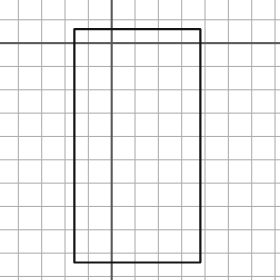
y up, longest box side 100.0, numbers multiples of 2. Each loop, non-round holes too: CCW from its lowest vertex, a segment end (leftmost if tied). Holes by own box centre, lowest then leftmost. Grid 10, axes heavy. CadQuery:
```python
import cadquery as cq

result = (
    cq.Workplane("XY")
    .moveTo(-16.0, -94.0)
    .lineTo(38.0, -94.0)
    .lineTo(38.0, 6.0)
    .lineTo(-16.0, 6.0)
    .close()
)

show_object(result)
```